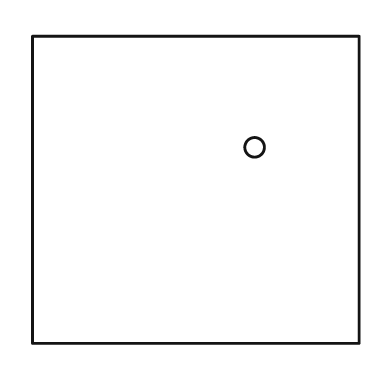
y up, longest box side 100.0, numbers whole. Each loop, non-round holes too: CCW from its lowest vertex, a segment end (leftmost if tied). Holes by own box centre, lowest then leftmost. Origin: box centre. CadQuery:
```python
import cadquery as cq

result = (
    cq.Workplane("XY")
    .moveTo(-50.0, -47.0)
    .lineTo(50.0, -47.0)
    .lineTo(50.0, 47.0)
    .lineTo(-50.0, 47.0)
    .close()
    .moveTo(18.0, 13.0)
    .circle(3.0)
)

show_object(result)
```